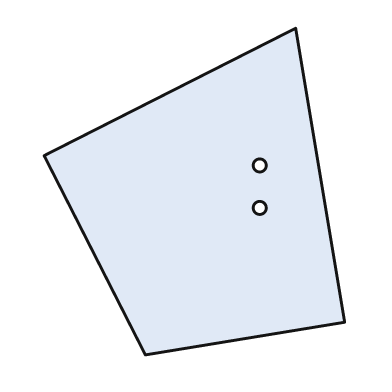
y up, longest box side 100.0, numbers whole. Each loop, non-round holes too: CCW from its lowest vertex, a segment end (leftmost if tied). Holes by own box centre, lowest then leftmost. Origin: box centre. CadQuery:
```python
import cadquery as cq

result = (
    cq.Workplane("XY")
    .moveTo(-15.0, -50.0)
    .lineTo(46.0, -40.0)
    .lineTo(31.0, 50.0)
    .lineTo(-46.0, 11.0)
    .close()
    .moveTo(20.0, -5.0)
    .circle(2.0)
    .moveTo(20.0, 8.0)
    .circle(2.0)
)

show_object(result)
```